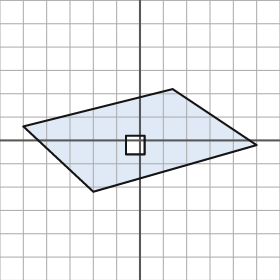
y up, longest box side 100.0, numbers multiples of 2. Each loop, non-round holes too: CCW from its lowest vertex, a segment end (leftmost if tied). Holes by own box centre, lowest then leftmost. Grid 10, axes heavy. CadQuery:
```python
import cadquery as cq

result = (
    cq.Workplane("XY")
    .moveTo(-20.0, -22.0)
    .lineTo(50.0, -2.0)
    .lineTo(14.0, 22.0)
    .lineTo(-50.0, 6.0)
    .close()
    .moveTo(-6.0, -6.0)
    .lineTo(2.0, -6.0)
    .lineTo(2.0, 2.0)
    .lineTo(-6.0, 2.0)
    .close()
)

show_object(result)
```